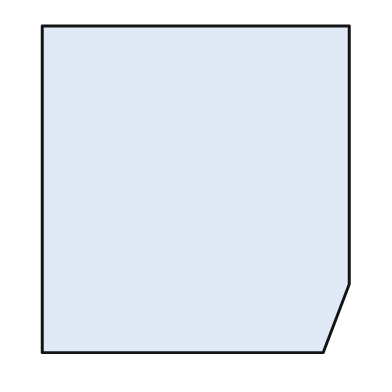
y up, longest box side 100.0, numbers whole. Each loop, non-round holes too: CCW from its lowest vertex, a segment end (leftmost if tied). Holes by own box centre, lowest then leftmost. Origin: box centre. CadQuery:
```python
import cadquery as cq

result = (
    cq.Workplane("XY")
    .moveTo(-47.0, -50.0)
    .lineTo(39.0, -50.0)
    .lineTo(47.0, -29.0)
    .lineTo(47.0, 50.0)
    .lineTo(-47.0, 50.0)
    .close()
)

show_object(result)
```